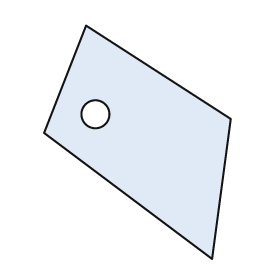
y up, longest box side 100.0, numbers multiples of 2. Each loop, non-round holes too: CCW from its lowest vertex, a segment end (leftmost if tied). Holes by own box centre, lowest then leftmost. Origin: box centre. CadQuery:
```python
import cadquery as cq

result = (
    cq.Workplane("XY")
    .moveTo(32.0, -50.0)
    .lineTo(40.0, 10.0)
    .lineTo(-22.0, 50.0)
    .lineTo(-40.0, 4.0)
    .close()
    .moveTo(-18.0, 12.0)
    .circle(6.0)
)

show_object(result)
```